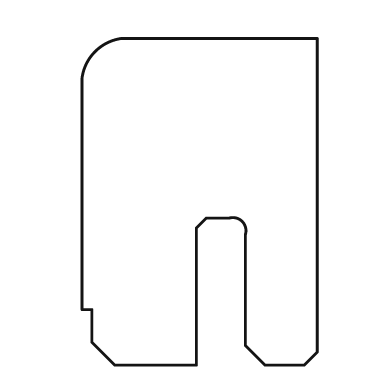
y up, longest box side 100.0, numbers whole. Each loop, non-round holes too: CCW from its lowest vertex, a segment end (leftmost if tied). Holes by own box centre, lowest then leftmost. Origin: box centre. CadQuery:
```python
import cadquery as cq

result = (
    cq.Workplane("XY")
    .moveTo(-26.0, -50.0)
    .lineTo(-1.0, -50.0)
    .lineTo(-1.0, -8.0)
    .lineTo(2.0, -5.0)
    .lineTo(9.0, -5.0)
    .threePointArc((13.0, -6.0), (14.0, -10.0))
    .lineTo(14.0, -44.0)
    .lineTo(20.0, -50.0)
    .lineTo(32.0, -50.0)
    .lineTo(36.0, -46.0)
    .lineTo(36.0, 50.0)
    .lineTo(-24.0, 50.0)
    .threePointArc((-32.0, 46.0), (-36.0, 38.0))
    .lineTo(-36.0, -33.0)
    .lineTo(-33.0, -33.0)
    .lineTo(-33.0, -43.0)
    .close()
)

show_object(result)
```